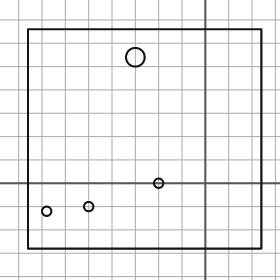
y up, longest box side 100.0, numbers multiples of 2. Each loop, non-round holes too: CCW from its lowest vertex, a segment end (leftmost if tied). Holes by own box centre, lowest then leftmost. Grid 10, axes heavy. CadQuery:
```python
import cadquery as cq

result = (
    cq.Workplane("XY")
    .moveTo(-76.0, -28.0)
    .lineTo(24.0, -28.0)
    .lineTo(24.0, 66.0)
    .lineTo(-76.0, 66.0)
    .close()
    .moveTo(-68.0, -12.0)
    .circle(2.0)
    .moveTo(-50.0, -10.0)
    .circle(2.0)
    .moveTo(-20.0, 0.0)
    .circle(2.0)
    .moveTo(-30.0, 54.0)
    .circle(4.0)
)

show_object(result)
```